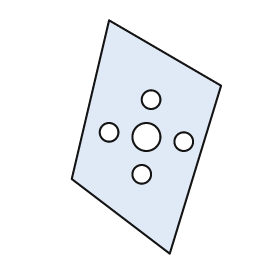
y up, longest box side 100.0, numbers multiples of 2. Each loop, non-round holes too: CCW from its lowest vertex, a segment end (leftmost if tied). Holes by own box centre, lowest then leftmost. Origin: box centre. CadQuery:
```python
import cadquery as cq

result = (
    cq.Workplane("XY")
    .moveTo(10.0, -50.0)
    .lineTo(32.0, 22.0)
    .lineTo(-16.0, 50.0)
    .lineTo(-32.0, -18.0)
    .close()
    .moveTo(-2.0, -16.0)
    .circle(4.0)
    .moveTo(16.0, -2.0)
    .circle(4.0)
    .moveTo(0.0, 0.0)
    .circle(6.0)
    .moveTo(-16.0, 2.0)
    .circle(4.0)
    .moveTo(2.0, 16.0)
    .circle(4.0)
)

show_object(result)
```